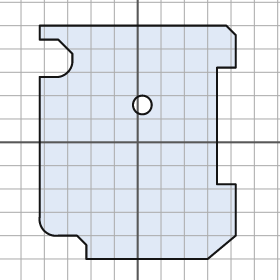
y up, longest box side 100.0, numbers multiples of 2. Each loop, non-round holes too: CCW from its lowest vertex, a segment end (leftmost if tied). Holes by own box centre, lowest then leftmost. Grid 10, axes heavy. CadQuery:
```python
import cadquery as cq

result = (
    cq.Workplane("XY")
    .moveTo(-22.0, -50.0)
    .lineTo(30.0, -50.0)
    .lineTo(42.0, -40.0)
    .lineTo(42.0, -18.0)
    .lineTo(34.0, -18.0)
    .lineTo(34.0, 32.0)
    .lineTo(42.0, 32.0)
    .lineTo(42.0, 46.0)
    .lineTo(38.0, 50.0)
    .lineTo(-42.0, 50.0)
    .lineTo(-42.0, 44.0)
    .lineTo(-34.0, 44.0)
    .lineTo(-28.0, 38.0)
    .lineTo(-28.0, 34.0)
    .threePointArc((-30.0, 30.0), (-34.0, 28.0))
    .lineTo(-42.0, 28.0)
    .lineTo(-42.0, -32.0)
    .threePointArc((-40.0, -38.0), (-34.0, -40.0))
    .lineTo(-26.0, -40.0)
    .lineTo(-22.0, -44.0)
    .close()
    .moveTo(2.0, 16.0)
    .circle(4.0)
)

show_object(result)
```